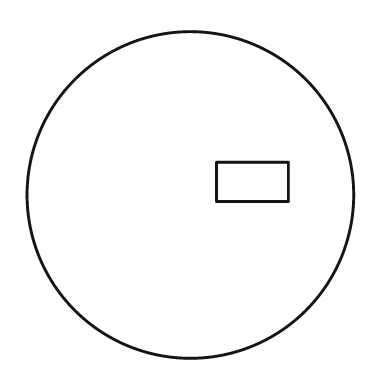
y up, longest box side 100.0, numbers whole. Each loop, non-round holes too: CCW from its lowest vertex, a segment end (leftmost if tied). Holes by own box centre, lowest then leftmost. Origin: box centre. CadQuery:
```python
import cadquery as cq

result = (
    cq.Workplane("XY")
    .moveTo(0.0, 0.0)
    .circle(50.0)
    .moveTo(8.0, -2.0)
    .lineTo(30.0, -2.0)
    .lineTo(30.0, 10.0)
    .lineTo(8.0, 10.0)
    .close()
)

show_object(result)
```